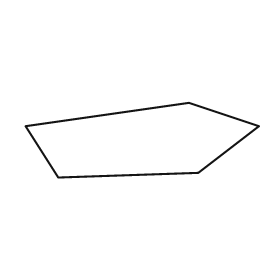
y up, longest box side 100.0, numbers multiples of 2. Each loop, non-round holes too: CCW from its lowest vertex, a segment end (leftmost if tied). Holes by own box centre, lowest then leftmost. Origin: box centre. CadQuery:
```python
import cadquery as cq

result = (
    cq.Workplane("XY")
    .moveTo(-36.0, -16.0)
    .lineTo(24.0, -14.0)
    .lineTo(50.0, 6.0)
    .lineTo(20.0, 16.0)
    .lineTo(-50.0, 6.0)
    .close()
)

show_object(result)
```